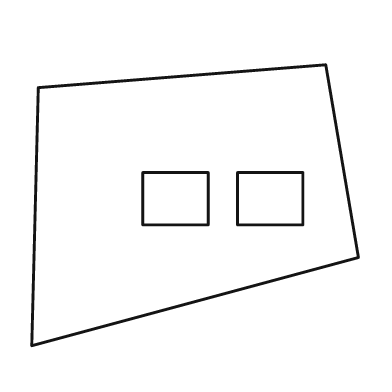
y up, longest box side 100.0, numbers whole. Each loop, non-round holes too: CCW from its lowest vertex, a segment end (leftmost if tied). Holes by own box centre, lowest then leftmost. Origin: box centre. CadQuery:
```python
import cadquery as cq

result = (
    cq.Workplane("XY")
    .moveTo(-50.0, -43.0)
    .lineTo(50.0, -16.0)
    .lineTo(40.0, 43.0)
    .lineTo(-48.0, 36.0)
    .close()
    .moveTo(-16.0, -6.0)
    .lineTo(4.0, -6.0)
    .lineTo(4.0, 10.0)
    .lineTo(-16.0, 10.0)
    .close()
    .moveTo(13.0, -6.0)
    .lineTo(33.0, -6.0)
    .lineTo(33.0, 10.0)
    .lineTo(13.0, 10.0)
    .close()
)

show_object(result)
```